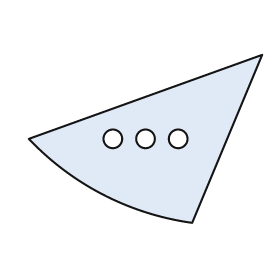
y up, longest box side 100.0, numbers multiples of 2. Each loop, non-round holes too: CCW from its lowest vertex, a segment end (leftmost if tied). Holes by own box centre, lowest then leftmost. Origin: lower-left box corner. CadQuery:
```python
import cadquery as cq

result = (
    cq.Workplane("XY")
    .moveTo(70.0, 0.0)
    .lineTo(100.0, 72.0)
    .lineTo(0.0, 36.0)
    .threePointArc((32.0, 12.0), (70.0, 0.0))
    .close()
    .moveTo(36.0, 36.0)
    .circle(4.0)
    .moveTo(50.0, 36.0)
    .circle(4.0)
    .moveTo(64.0, 36.0)
    .circle(4.0)
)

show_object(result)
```